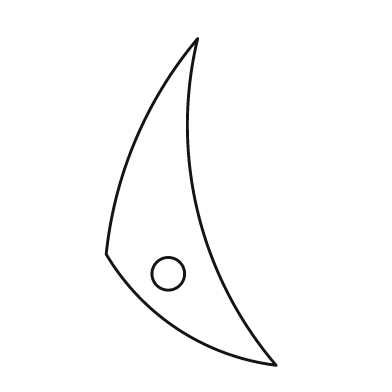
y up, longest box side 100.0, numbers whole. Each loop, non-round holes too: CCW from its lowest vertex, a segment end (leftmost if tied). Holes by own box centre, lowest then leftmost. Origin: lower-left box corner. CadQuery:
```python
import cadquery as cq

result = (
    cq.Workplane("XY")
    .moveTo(52.0, 0.0)
    .threePointArc((28.0, 47.0), (28.0, 100.0))
    .threePointArc((9.0, 69.0), (0.0, 34.0))
    .threePointArc((22.0, 11.0), (52.0, 0.0))
    .close()
    .moveTo(19.0, 28.0)
    .circle(5.0)
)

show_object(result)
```